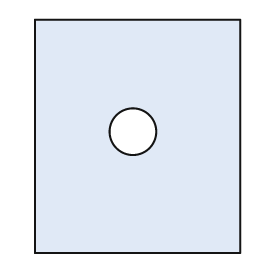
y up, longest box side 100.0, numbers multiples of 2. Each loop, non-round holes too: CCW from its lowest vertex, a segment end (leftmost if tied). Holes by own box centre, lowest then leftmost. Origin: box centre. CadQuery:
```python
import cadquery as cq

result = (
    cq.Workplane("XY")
    .moveTo(-44.0, -50.0)
    .lineTo(44.0, -50.0)
    .lineTo(44.0, 50.0)
    .lineTo(-44.0, 50.0)
    .close()
    .moveTo(-2.0, 2.0)
    .circle(10.0)
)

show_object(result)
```